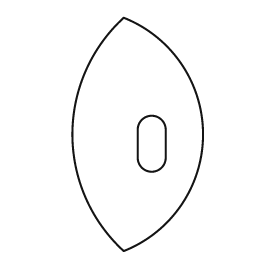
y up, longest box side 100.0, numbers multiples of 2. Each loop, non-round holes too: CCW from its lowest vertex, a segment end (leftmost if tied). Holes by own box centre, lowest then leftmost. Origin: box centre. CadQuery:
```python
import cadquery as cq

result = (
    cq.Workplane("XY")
    .moveTo(-6.0, -50.0)
    .threePointArc((28.0, 0.0), (-6.0, 50.0))
    .threePointArc((-28.0, 0.0), (-6.0, -50.0))
    .close()
    .moveTo(0.0, -10.0)
    .threePointArc((6.0, -16.0), (12.0, -10.0))
    .lineTo(12.0, 2.0)
    .threePointArc((6.0, 8.0), (0.0, 2.0))
    .close()
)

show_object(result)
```